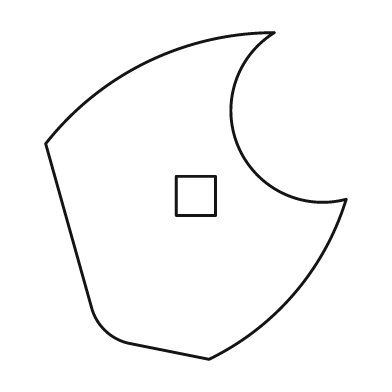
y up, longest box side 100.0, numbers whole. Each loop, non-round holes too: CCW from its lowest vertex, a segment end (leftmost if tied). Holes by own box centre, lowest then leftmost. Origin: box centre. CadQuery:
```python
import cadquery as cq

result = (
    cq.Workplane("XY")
    .moveTo(4.0, -50.0)
    .threePointArc((30.0, -30.0), (46.0, -1.0))
    .threePointArc((13.0, 15.0), (24.0, 50.0))
    .threePointArc((-15.0, 41.0), (-46.0, 16.0))
    .lineTo(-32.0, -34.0)
    .threePointArc((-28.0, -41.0), (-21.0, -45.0))
    .close()
    .moveTo(-6.0, -6.0)
    .lineTo(6.0, -6.0)
    .lineTo(6.0, 6.0)
    .lineTo(-6.0, 6.0)
    .close()
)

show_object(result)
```